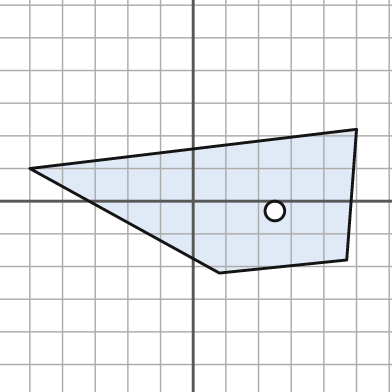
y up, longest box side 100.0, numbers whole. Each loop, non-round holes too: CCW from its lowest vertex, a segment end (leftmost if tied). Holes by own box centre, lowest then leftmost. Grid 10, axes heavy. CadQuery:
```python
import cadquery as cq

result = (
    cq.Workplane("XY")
    .moveTo(8.0, -22.0)
    .lineTo(47.0, -18.0)
    .lineTo(50.0, 22.0)
    .lineTo(-50.0, 10.0)
    .close()
    .moveTo(25.0, -3.0)
    .circle(3.0)
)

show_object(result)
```